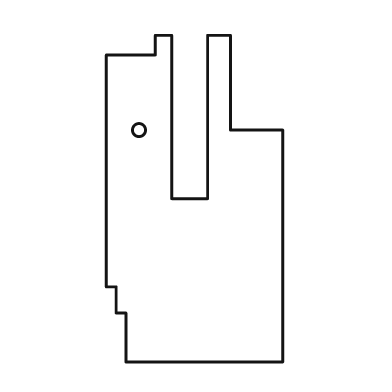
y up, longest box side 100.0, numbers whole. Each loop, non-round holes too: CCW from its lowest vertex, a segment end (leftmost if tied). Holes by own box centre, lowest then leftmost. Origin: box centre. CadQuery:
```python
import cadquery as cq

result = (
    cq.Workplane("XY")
    .moveTo(-21.0, -50.0)
    .lineTo(27.0, -50.0)
    .lineTo(27.0, 21.0)
    .lineTo(11.0, 21.0)
    .lineTo(11.0, 50.0)
    .lineTo(4.0, 50.0)
    .lineTo(4.0, 0.0)
    .lineTo(-7.0, 0.0)
    .lineTo(-7.0, 50.0)
    .lineTo(-12.0, 50.0)
    .lineTo(-12.0, 44.0)
    .lineTo(-27.0, 44.0)
    .lineTo(-27.0, -27.0)
    .lineTo(-24.0, -27.0)
    .lineTo(-24.0, -35.0)
    .lineTo(-21.0, -35.0)
    .close()
    .moveTo(-17.0, 21.0)
    .circle(2.0)
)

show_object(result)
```